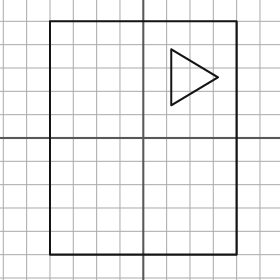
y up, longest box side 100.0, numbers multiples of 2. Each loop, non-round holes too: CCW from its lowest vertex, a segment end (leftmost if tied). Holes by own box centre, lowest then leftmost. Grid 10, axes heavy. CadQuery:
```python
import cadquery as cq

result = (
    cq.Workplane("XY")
    .moveTo(-40.0, -50.0)
    .lineTo(40.0, -50.0)
    .lineTo(40.0, 50.0)
    .lineTo(-40.0, 50.0)
    .close()
    .moveTo(12.0, 14.0)
    .lineTo(32.0, 26.0)
    .lineTo(12.0, 38.0)
    .close()
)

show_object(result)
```